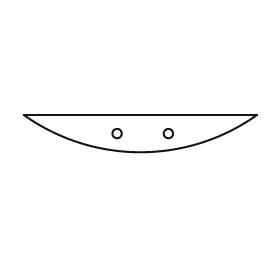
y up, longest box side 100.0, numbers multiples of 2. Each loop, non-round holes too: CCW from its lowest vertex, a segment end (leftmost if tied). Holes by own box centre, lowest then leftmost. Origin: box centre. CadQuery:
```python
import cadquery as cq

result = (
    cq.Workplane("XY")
    .moveTo(-50.0, 8.0)
    .threePointArc((0.0, -8.0), (50.0, 8.0))
    .close()
    .moveTo(-10.0, 0.0)
    .circle(2.0)
    .moveTo(12.0, 0.0)
    .circle(2.0)
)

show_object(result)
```